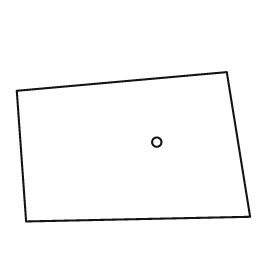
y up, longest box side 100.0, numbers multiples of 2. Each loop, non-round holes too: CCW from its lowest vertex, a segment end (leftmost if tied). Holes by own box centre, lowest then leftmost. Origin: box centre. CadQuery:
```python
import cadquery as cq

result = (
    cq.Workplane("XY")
    .moveTo(-46.0, -32.0)
    .lineTo(50.0, -30.0)
    .lineTo(40.0, 32.0)
    .lineTo(-50.0, 24.0)
    .close()
    .moveTo(10.0, 2.0)
    .circle(2.0)
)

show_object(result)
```